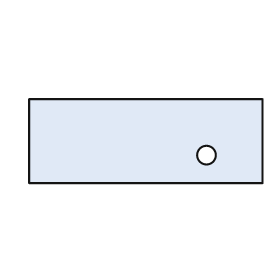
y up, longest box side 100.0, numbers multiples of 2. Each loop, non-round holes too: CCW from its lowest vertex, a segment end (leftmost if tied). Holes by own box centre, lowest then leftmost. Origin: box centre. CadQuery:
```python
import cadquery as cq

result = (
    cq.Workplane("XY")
    .moveTo(-50.0, -18.0)
    .lineTo(50.0, -18.0)
    .lineTo(50.0, 18.0)
    .lineTo(-50.0, 18.0)
    .close()
    .moveTo(26.0, -6.0)
    .circle(4.0)
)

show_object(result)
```